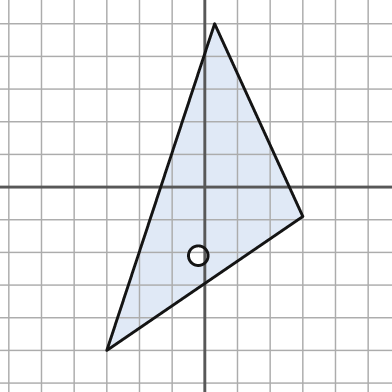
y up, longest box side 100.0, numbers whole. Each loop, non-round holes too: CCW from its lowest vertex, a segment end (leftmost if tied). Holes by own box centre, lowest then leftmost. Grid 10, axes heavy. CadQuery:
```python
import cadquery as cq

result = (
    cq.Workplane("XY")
    .moveTo(-30.0, -50.0)
    .lineTo(30.0, -9.0)
    .lineTo(3.0, 50.0)
    .close()
    .moveTo(-2.0, -21.0)
    .circle(3.0)
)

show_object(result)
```